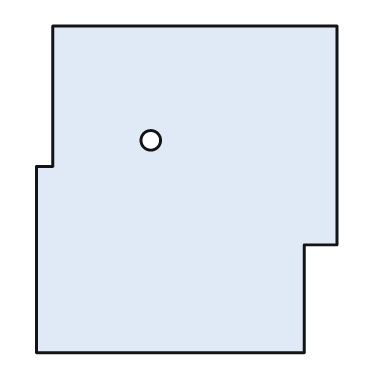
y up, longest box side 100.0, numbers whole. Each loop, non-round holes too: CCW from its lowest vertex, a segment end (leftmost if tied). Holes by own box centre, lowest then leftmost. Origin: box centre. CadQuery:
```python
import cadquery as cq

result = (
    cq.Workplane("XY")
    .moveTo(-46.0, -50.0)
    .lineTo(36.0, -50.0)
    .lineTo(36.0, -17.0)
    .lineTo(46.0, -17.0)
    .lineTo(46.0, 50.0)
    .lineTo(-41.0, 50.0)
    .lineTo(-41.0, 7.0)
    .lineTo(-46.0, 7.0)
    .close()
    .moveTo(-11.0, 15.0)
    .circle(3.0)
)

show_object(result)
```